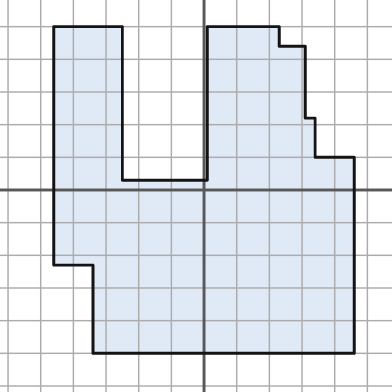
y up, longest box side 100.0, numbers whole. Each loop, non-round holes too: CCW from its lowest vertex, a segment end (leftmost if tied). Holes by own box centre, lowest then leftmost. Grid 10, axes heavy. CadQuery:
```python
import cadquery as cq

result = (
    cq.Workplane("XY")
    .moveTo(-34.0, -50.0)
    .lineTo(46.0, -50.0)
    .lineTo(46.0, 10.0)
    .lineTo(34.0, 10.0)
    .lineTo(34.0, 22.0)
    .lineTo(31.0, 22.0)
    .lineTo(31.0, 44.0)
    .lineTo(23.0, 44.0)
    .lineTo(23.0, 50.0)
    .lineTo(1.0, 50.0)
    .lineTo(1.0, 3.0)
    .lineTo(-25.0, 3.0)
    .lineTo(-25.0, 50.0)
    .lineTo(-46.0, 50.0)
    .lineTo(-46.0, -23.0)
    .lineTo(-34.0, -23.0)
    .close()
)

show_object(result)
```